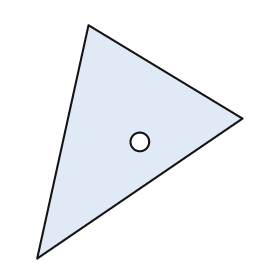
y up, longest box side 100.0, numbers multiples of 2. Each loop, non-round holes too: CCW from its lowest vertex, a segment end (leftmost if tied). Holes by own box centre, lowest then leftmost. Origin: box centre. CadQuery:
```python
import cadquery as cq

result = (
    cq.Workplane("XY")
    .moveTo(-44.0, -50.0)
    .lineTo(44.0, 10.0)
    .lineTo(-22.0, 50.0)
    .close()
    .moveTo(0.0, 0.0)
    .circle(4.0)
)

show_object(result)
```